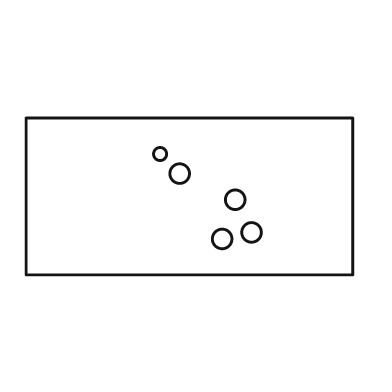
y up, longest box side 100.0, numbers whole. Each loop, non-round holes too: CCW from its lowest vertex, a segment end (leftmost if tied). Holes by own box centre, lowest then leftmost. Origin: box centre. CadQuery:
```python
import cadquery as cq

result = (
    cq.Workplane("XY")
    .moveTo(-50.0, -24.0)
    .lineTo(50.0, -24.0)
    .lineTo(50.0, 24.0)
    .lineTo(-50.0, 24.0)
    .close()
    .moveTo(10.0, -13.0)
    .circle(3.0)
    .moveTo(19.0, -11.0)
    .circle(3.0)
    .moveTo(14.0, -1.0)
    .circle(3.0)
    .moveTo(-3.0, 7.0)
    .circle(3.0)
    .moveTo(-9.0, 13.0)
    .circle(2.0)
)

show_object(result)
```